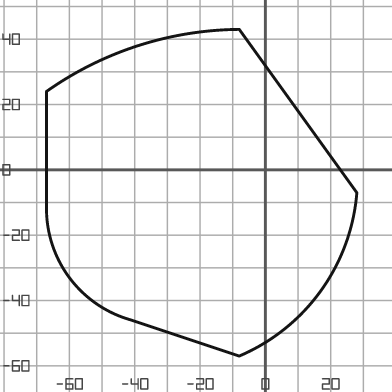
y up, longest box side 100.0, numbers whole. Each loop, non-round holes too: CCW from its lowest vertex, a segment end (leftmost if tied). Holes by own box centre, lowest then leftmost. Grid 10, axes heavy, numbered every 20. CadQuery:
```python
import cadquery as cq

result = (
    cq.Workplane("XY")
    .moveTo(-8.0, -57.0)
    .threePointArc((17.0, -37.0), (28.0, -7.0))
    .lineTo(-8.0, 43.0)
    .threePointArc((-39.0, 38.0), (-67.0, 24.0))
    .lineTo(-67.0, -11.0)
    .threePointArc((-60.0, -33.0), (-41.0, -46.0))
    .close()
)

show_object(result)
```